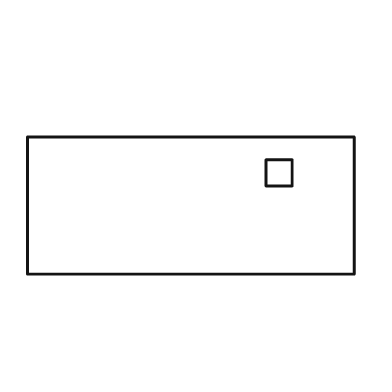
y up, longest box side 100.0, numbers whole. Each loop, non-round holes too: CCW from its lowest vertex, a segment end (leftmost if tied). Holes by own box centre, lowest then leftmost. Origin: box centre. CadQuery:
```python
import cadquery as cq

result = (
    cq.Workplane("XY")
    .moveTo(-50.0, -21.0)
    .lineTo(50.0, -21.0)
    .lineTo(50.0, 21.0)
    .lineTo(-50.0, 21.0)
    .close()
    .moveTo(23.0, 6.0)
    .lineTo(31.0, 6.0)
    .lineTo(31.0, 14.0)
    .lineTo(23.0, 14.0)
    .close()
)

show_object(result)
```